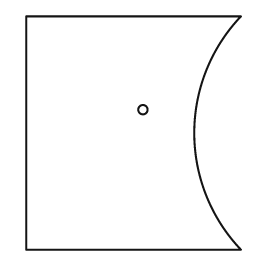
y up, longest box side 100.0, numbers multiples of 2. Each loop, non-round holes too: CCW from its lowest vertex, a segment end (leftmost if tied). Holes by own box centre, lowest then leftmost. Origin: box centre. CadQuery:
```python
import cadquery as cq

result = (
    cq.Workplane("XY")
    .moveTo(-46.0, -50.0)
    .lineTo(46.0, -50.0)
    .threePointArc((26.0, 0.0), (46.0, 50.0))
    .lineTo(-46.0, 50.0)
    .close()
    .moveTo(4.0, 10.0)
    .circle(2.0)
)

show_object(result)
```